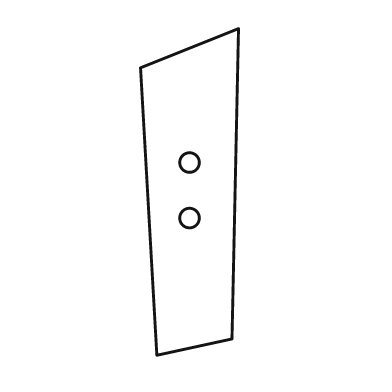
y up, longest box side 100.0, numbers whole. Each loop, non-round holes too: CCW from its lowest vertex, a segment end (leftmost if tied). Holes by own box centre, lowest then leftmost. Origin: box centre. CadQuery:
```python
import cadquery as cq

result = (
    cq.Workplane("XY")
    .moveTo(-10.0, -50.0)
    .lineTo(13.0, -45.0)
    .lineTo(15.0, 50.0)
    .lineTo(-15.0, 38.0)
    .close()
    .moveTo(0.0, -8.0)
    .circle(3.0)
    .moveTo(0.0, 9.0)
    .circle(3.0)
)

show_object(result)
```